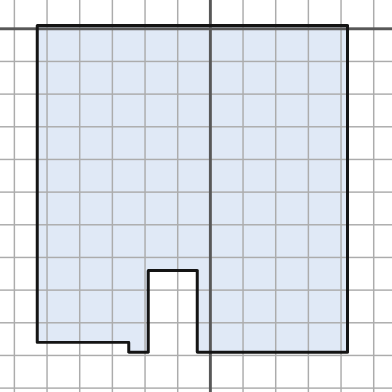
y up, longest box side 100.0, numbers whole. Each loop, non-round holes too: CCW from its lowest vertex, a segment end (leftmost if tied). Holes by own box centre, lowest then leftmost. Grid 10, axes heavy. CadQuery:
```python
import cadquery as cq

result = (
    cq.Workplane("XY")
    .moveTo(-25.0, -99.0)
    .lineTo(-19.0, -99.0)
    .lineTo(-19.0, -74.0)
    .lineTo(-4.0, -74.0)
    .lineTo(-4.0, -99.0)
    .lineTo(42.0, -99.0)
    .lineTo(42.0, 1.0)
    .lineTo(-53.0, 1.0)
    .lineTo(-53.0, -96.0)
    .lineTo(-25.0, -96.0)
    .close()
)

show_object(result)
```